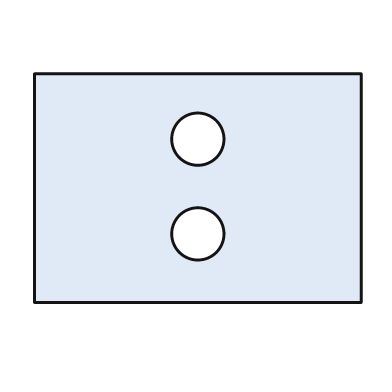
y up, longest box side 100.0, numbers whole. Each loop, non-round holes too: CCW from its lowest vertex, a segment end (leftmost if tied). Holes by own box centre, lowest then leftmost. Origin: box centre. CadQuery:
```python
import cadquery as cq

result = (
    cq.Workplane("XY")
    .moveTo(-50.0, -35.0)
    .lineTo(50.0, -35.0)
    .lineTo(50.0, 35.0)
    .lineTo(-50.0, 35.0)
    .close()
    .moveTo(0.0, -14.0)
    .circle(8.0)
    .moveTo(0.0, 15.0)
    .circle(8.0)
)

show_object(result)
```